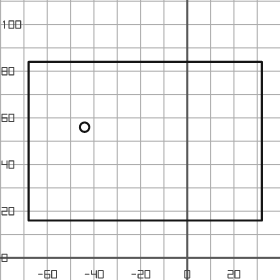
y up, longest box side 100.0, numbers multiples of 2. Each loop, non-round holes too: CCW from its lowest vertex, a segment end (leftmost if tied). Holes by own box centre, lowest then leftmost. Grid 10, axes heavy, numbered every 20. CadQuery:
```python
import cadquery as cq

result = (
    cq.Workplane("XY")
    .moveTo(-68.0, 16.0)
    .lineTo(32.0, 16.0)
    .lineTo(32.0, 84.0)
    .lineTo(-68.0, 84.0)
    .close()
    .moveTo(-44.0, 56.0)
    .circle(2.0)
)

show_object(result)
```